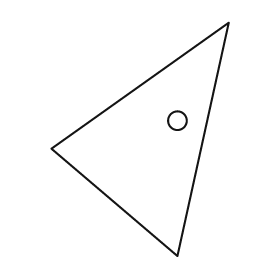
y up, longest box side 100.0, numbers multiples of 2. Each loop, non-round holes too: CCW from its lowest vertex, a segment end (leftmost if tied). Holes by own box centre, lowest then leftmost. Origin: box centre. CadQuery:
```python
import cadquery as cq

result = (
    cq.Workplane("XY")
    .moveTo(16.0, -50.0)
    .lineTo(38.0, 50.0)
    .lineTo(-38.0, -4.0)
    .close()
    .moveTo(16.0, 8.0)
    .circle(4.0)
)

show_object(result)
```